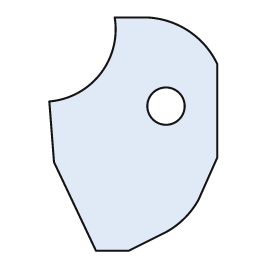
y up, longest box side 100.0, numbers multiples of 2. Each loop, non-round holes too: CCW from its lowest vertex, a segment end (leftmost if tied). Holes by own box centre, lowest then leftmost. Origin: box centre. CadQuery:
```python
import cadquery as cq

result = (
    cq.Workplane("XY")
    .moveTo(-16.0, -50.0)
    .lineTo(-2.0, -50.0)
    .lineTo(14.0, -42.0)
    .threePointArc((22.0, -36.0), (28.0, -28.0))
    .lineTo(36.0, -10.0)
    .lineTo(36.0, 30.0)
    .threePointArc((24.0, 44.0), (6.0, 50.0))
    .lineTo(-8.0, 50.0)
    .threePointArc((-14.0, 26.0), (-36.0, 14.0))
    .lineTo(-34.0, -12.0)
    .close()
    .moveTo(14.0, 12.0)
    .circle(8.0)
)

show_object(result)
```